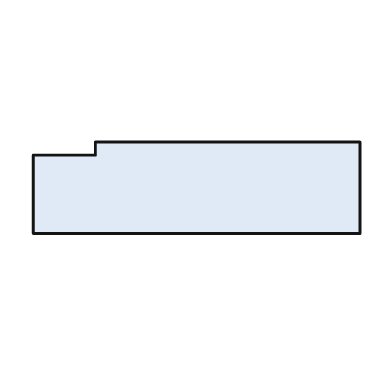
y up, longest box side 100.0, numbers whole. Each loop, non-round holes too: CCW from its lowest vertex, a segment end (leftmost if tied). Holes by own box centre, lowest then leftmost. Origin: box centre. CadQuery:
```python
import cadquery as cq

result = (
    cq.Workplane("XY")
    .moveTo(-50.0, -14.0)
    .lineTo(50.0, -14.0)
    .lineTo(50.0, 14.0)
    .lineTo(-31.0, 14.0)
    .lineTo(-31.0, 10.0)
    .lineTo(-50.0, 10.0)
    .close()
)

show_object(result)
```